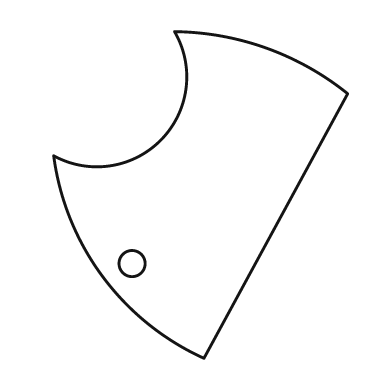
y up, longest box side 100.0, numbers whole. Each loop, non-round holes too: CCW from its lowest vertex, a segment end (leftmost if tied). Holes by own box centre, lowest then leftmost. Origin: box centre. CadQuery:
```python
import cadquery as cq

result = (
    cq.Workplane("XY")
    .moveTo(1.0, -50.0)
    .lineTo(45.0, 31.0)
    .threePointArc((20.0, 45.0), (-8.0, 50.0))
    .threePointArc((-12.0, 17.0), (-45.0, 12.0))
    .threePointArc((-30.0, -25.0), (1.0, -50.0))
    .close()
    .moveTo(-21.0, -21.0)
    .circle(4.0)
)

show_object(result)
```